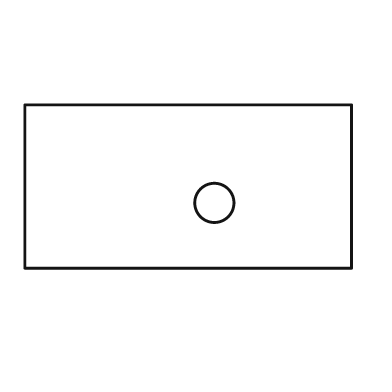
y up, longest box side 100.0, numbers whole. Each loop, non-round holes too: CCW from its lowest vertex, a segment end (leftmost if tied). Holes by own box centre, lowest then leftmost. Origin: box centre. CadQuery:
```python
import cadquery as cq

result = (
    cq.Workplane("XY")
    .moveTo(-50.0, -25.0)
    .lineTo(50.0, -25.0)
    .lineTo(50.0, 25.0)
    .lineTo(-50.0, 25.0)
    .close()
    .moveTo(8.0, -5.0)
    .circle(6.0)
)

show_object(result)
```